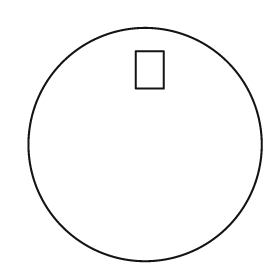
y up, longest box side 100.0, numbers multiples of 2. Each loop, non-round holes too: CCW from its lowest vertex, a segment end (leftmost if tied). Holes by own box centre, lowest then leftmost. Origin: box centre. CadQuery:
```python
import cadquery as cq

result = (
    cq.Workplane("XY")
    .moveTo(0.0, 0.0)
    .circle(50.0)
    .moveTo(-4.0, 24.0)
    .lineTo(8.0, 24.0)
    .lineTo(8.0, 40.0)
    .lineTo(-4.0, 40.0)
    .close()
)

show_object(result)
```